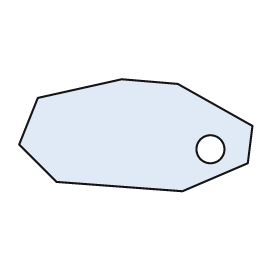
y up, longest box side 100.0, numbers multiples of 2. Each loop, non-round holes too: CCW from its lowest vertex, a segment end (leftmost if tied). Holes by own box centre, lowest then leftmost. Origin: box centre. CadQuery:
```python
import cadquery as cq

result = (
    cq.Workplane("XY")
    .moveTo(20.0, -24.0)
    .lineTo(48.0, -12.0)
    .lineTo(50.0, 4.0)
    .lineTo(18.0, 22.0)
    .lineTo(-6.0, 24.0)
    .lineTo(-42.0, 16.0)
    .lineTo(-50.0, -4.0)
    .lineTo(-34.0, -20.0)
    .close()
    .moveTo(32.0, -6.0)
    .circle(6.0)
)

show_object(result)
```